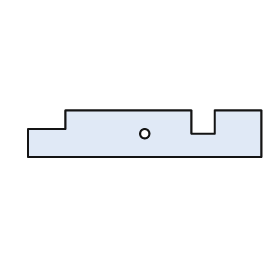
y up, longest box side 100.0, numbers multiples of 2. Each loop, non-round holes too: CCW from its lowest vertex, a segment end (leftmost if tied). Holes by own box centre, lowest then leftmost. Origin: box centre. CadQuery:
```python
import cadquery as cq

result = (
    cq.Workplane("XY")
    .moveTo(-50.0, -10.0)
    .lineTo(50.0, -10.0)
    .lineTo(50.0, 10.0)
    .lineTo(30.0, 10.0)
    .lineTo(30.0, 0.0)
    .lineTo(20.0, 0.0)
    .lineTo(20.0, 10.0)
    .lineTo(-34.0, 10.0)
    .lineTo(-34.0, 2.0)
    .lineTo(-50.0, 2.0)
    .close()
    .moveTo(0.0, 0.0)
    .circle(2.0)
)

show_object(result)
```